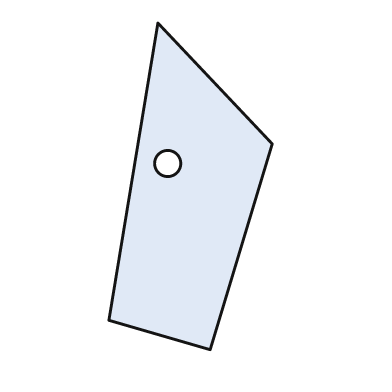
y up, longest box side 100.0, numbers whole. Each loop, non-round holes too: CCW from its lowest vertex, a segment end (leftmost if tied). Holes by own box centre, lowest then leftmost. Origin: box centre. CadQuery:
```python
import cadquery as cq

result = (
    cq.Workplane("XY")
    .moveTo(6.0, -50.0)
    .lineTo(25.0, 13.0)
    .lineTo(-10.0, 50.0)
    .lineTo(-25.0, -41.0)
    .close()
    .moveTo(-7.0, 7.0)
    .circle(4.0)
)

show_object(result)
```